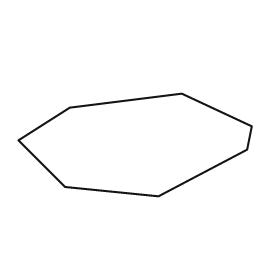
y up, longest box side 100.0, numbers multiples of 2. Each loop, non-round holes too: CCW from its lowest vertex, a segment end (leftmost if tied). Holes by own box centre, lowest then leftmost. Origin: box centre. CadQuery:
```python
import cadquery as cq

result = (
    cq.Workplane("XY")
    .moveTo(10.0, -22.0)
    .lineTo(48.0, -2.0)
    .lineTo(50.0, 8.0)
    .lineTo(20.0, 22.0)
    .lineTo(-28.0, 16.0)
    .lineTo(-50.0, 2.0)
    .lineTo(-30.0, -18.0)
    .close()
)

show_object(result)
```